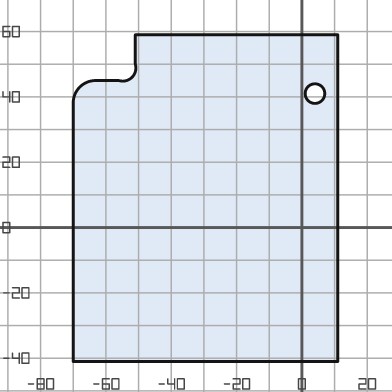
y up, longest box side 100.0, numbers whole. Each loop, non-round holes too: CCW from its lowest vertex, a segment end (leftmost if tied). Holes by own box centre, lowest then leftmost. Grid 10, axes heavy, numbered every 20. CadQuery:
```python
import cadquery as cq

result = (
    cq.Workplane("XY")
    .moveTo(-70.0, -41.0)
    .lineTo(11.0, -41.0)
    .lineTo(11.0, 59.0)
    .lineTo(-51.0, 59.0)
    .lineTo(-51.0, 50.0)
    .threePointArc((-52.0, 46.0), (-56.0, 45.0))
    .lineTo(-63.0, 45.0)
    .threePointArc((-68.0, 43.0), (-70.0, 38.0))
    .close()
    .moveTo(4.0, 41.0)
    .circle(3.0)
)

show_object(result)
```